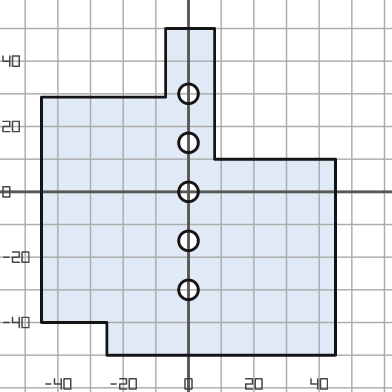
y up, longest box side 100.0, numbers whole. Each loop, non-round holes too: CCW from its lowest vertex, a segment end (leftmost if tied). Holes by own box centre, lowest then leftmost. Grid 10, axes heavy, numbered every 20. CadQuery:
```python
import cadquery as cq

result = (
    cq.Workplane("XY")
    .moveTo(-25.0, -50.0)
    .lineTo(45.0, -50.0)
    .lineTo(45.0, 10.0)
    .lineTo(8.0, 10.0)
    .lineTo(8.0, 50.0)
    .lineTo(-7.0, 50.0)
    .lineTo(-7.0, 29.0)
    .lineTo(-45.0, 29.0)
    .lineTo(-45.0, -40.0)
    .lineTo(-25.0, -40.0)
    .close()
    .moveTo(0.0, -30.0)
    .circle(3.0)
    .moveTo(0.0, -15.0)
    .circle(3.0)
    .moveTo(0.0, 0.0)
    .circle(3.0)
    .moveTo(0.0, 15.0)
    .circle(3.0)
    .moveTo(0.0, 30.0)
    .circle(3.0)
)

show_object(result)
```